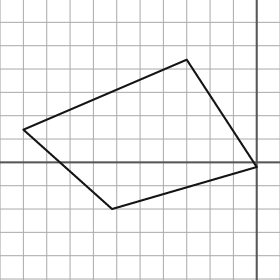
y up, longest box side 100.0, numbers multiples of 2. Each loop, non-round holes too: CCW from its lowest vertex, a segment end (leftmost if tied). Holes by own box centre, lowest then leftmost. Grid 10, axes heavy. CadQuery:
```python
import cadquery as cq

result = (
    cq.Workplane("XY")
    .moveTo(-62.0, -20.0)
    .lineTo(0.0, -2.0)
    .lineTo(-30.0, 44.0)
    .lineTo(-100.0, 14.0)
    .close()
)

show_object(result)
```